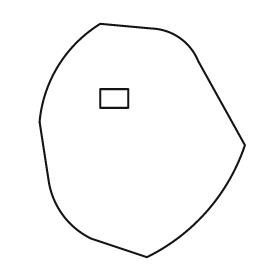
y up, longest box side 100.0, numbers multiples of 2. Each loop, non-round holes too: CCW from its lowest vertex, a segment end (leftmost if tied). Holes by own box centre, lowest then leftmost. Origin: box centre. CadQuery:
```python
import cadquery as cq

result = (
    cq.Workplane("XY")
    .moveTo(2.0, -50.0)
    .threePointArc((28.0, -30.0), (44.0, -2.0))
    .lineTo(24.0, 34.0)
    .threePointArc((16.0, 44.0), (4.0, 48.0))
    .lineTo(-18.0, 50.0)
    .threePointArc((-36.0, 32.0), (-44.0, 8.0))
    .lineTo(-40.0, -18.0)
    .threePointArc((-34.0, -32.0), (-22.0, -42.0))
    .close()
    .moveTo(-18.0, 14.0)
    .lineTo(-6.0, 14.0)
    .lineTo(-6.0, 22.0)
    .lineTo(-18.0, 22.0)
    .close()
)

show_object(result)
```